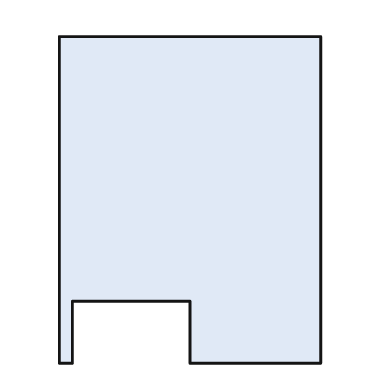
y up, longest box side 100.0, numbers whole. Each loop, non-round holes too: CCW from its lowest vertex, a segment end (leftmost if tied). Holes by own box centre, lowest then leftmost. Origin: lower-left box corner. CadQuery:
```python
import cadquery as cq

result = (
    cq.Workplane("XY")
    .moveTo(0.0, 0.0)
    .lineTo(4.0, 0.0)
    .lineTo(4.0, 19.0)
    .lineTo(40.0, 19.0)
    .lineTo(40.0, 0.0)
    .lineTo(80.0, 0.0)
    .lineTo(80.0, 100.0)
    .lineTo(0.0, 100.0)
    .close()
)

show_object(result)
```